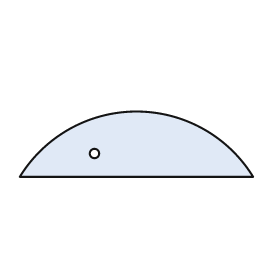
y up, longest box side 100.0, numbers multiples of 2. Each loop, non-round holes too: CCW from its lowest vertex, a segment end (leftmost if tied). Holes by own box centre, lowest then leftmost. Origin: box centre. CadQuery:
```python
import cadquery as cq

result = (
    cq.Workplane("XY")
    .moveTo(-50.0, -14.0)
    .lineTo(50.0, -14.0)
    .threePointArc((0.0, 14.0), (-50.0, -14.0))
    .close()
    .moveTo(-18.0, -4.0)
    .circle(2.0)
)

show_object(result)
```